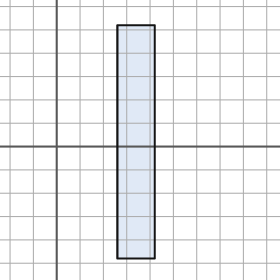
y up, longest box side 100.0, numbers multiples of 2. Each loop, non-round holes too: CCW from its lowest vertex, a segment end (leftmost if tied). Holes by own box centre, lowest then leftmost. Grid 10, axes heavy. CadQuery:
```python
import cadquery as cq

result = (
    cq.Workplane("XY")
    .moveTo(26.0, -48.0)
    .lineTo(42.0, -48.0)
    .lineTo(42.0, 52.0)
    .lineTo(26.0, 52.0)
    .close()
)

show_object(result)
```